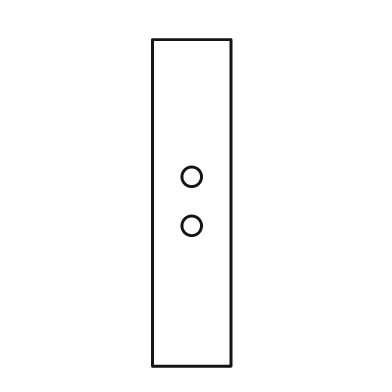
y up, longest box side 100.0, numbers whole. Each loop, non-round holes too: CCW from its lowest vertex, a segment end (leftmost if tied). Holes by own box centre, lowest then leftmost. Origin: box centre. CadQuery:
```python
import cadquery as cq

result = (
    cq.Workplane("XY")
    .moveTo(-12.0, -50.0)
    .lineTo(12.0, -50.0)
    .lineTo(12.0, 50.0)
    .lineTo(-12.0, 50.0)
    .close()
    .moveTo(0.0, -7.0)
    .circle(3.0)
    .moveTo(0.0, 8.0)
    .circle(3.0)
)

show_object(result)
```